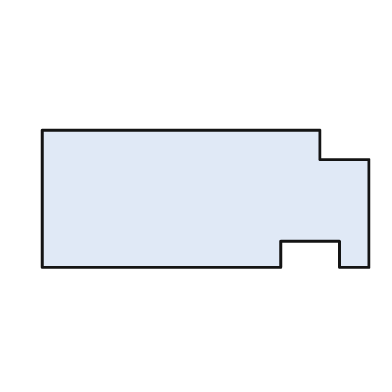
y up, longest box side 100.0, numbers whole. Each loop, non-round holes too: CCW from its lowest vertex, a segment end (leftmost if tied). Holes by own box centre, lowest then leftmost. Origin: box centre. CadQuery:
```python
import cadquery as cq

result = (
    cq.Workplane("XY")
    .moveTo(-50.0, -21.0)
    .lineTo(23.0, -21.0)
    .lineTo(23.0, -13.0)
    .lineTo(41.0, -13.0)
    .lineTo(41.0, -21.0)
    .lineTo(50.0, -21.0)
    .lineTo(50.0, 12.0)
    .lineTo(35.0, 12.0)
    .lineTo(35.0, 21.0)
    .lineTo(-50.0, 21.0)
    .close()
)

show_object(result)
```